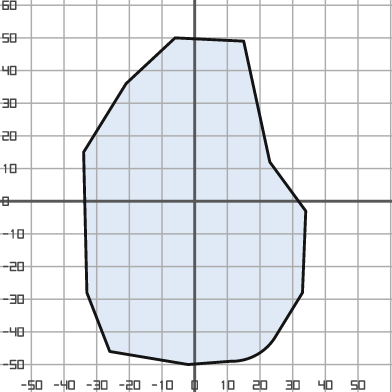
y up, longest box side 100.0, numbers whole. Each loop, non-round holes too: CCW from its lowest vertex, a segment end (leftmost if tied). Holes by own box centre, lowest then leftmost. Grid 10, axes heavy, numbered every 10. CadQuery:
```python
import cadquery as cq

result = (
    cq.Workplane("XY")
    .moveTo(-2.0, -50.0)
    .lineTo(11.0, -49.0)
    .threePointArc((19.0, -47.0), (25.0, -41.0))
    .lineTo(33.0, -28.0)
    .lineTo(34.0, -3.0)
    .lineTo(23.0, 12.0)
    .lineTo(15.0, 49.0)
    .lineTo(-6.0, 50.0)
    .lineTo(-21.0, 36.0)
    .lineTo(-34.0, 15.0)
    .lineTo(-33.0, -28.0)
    .lineTo(-26.0, -46.0)
    .close()
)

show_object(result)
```